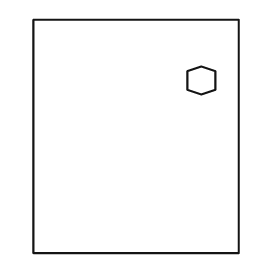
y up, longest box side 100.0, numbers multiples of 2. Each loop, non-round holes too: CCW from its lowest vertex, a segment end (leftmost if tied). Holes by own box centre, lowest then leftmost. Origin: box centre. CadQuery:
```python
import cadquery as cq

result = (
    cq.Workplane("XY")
    .moveTo(-44.0, -50.0)
    .lineTo(44.0, -50.0)
    .lineTo(44.0, 50.0)
    .lineTo(-44.0, 50.0)
    .close()
    .moveTo(28.0, 18.0)
    .lineTo(34.0, 20.0)
    .lineTo(34.0, 28.0)
    .lineTo(28.0, 30.0)
    .lineTo(22.0, 28.0)
    .lineTo(22.0, 20.0)
    .close()
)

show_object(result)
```